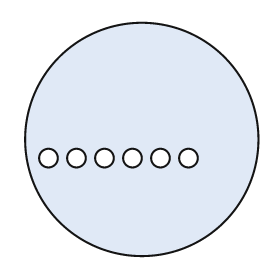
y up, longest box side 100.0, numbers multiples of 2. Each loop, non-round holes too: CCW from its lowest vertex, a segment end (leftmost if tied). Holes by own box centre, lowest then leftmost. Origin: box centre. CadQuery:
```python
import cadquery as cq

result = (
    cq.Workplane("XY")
    .moveTo(0.0, 0.0)
    .circle(50.0)
    .moveTo(-40.0, -8.0)
    .circle(4.0)
    .moveTo(-28.0, -8.0)
    .circle(4.0)
    .moveTo(-16.0, -8.0)
    .circle(4.0)
    .moveTo(-4.0, -8.0)
    .circle(4.0)
    .moveTo(8.0, -8.0)
    .circle(4.0)
    .moveTo(20.0, -8.0)
    .circle(4.0)
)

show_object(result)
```